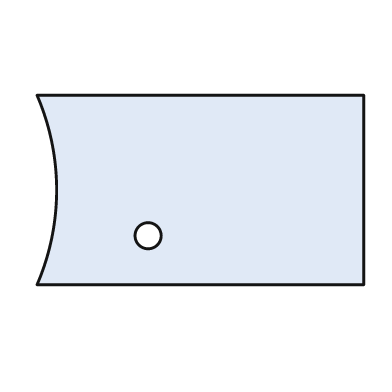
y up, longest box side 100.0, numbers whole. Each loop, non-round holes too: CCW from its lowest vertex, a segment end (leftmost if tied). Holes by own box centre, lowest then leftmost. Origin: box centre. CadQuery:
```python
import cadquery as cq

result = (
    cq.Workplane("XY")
    .moveTo(-50.0, -29.0)
    .lineTo(50.0, -29.0)
    .lineTo(50.0, 29.0)
    .lineTo(-50.0, 29.0)
    .threePointArc((-44.0, 0.0), (-50.0, -29.0))
    .close()
    .moveTo(-16.0, -14.0)
    .circle(4.0)
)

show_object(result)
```